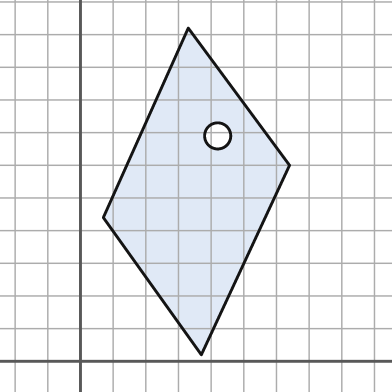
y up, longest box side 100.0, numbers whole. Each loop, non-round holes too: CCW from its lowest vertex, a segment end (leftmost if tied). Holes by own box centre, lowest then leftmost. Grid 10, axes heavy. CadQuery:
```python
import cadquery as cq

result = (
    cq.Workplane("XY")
    .moveTo(37.0, 2.0)
    .lineTo(64.0, 60.0)
    .lineTo(33.0, 102.0)
    .lineTo(7.0, 44.0)
    .close()
    .moveTo(42.0, 69.0)
    .circle(4.0)
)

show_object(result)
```